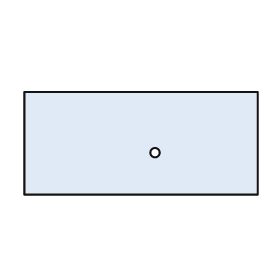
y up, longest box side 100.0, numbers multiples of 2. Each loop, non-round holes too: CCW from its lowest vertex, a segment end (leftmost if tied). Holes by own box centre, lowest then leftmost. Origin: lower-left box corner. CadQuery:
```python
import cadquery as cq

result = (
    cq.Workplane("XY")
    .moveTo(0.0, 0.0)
    .lineTo(100.0, 0.0)
    .lineTo(100.0, 44.0)
    .lineTo(0.0, 44.0)
    .close()
    .moveTo(56.0, 18.0)
    .circle(2.0)
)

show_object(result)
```